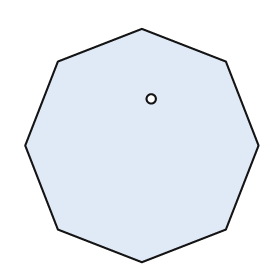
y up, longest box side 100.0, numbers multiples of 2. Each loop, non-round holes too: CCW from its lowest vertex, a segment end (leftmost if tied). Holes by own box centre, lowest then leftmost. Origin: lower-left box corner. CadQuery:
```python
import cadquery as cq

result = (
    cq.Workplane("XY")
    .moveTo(50.0, 0.0)
    .lineTo(86.0, 14.0)
    .lineTo(100.0, 50.0)
    .lineTo(86.0, 86.0)
    .lineTo(50.0, 100.0)
    .lineTo(14.0, 86.0)
    .lineTo(0.0, 50.0)
    .lineTo(14.0, 14.0)
    .close()
    .moveTo(54.0, 70.0)
    .circle(2.0)
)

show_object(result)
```